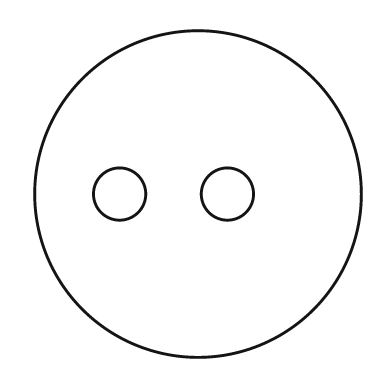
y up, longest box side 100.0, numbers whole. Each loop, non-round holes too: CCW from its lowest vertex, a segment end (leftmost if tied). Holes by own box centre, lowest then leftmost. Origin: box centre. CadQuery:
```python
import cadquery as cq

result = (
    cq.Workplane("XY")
    .moveTo(0.0, 0.0)
    .circle(50.0)
    .moveTo(-24.0, 0.0)
    .circle(8.0)
    .moveTo(9.0, 0.0)
    .circle(8.0)
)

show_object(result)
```